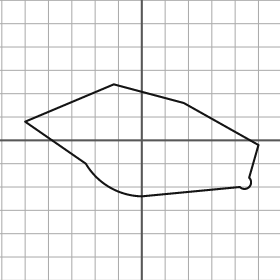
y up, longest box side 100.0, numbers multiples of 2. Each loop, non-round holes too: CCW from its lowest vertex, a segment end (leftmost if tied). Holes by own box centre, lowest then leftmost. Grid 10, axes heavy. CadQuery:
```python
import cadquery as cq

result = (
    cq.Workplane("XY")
    .moveTo(0.0, -24.0)
    .lineTo(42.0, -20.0)
    .threePointArc((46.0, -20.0), (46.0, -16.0))
    .lineTo(50.0, -2.0)
    .lineTo(18.0, 16.0)
    .lineTo(-12.0, 24.0)
    .lineTo(-50.0, 8.0)
    .lineTo(-24.0, -10.0)
    .threePointArc((-14.0, -20.0), (0.0, -24.0))
    .close()
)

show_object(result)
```